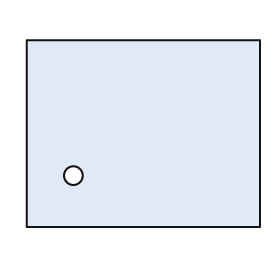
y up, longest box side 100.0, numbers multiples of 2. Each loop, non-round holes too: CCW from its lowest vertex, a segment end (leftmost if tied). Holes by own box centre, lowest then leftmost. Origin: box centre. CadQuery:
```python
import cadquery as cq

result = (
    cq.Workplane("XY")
    .moveTo(-50.0, -40.0)
    .lineTo(50.0, -40.0)
    .lineTo(50.0, 40.0)
    .lineTo(-50.0, 40.0)
    .close()
    .moveTo(-30.0, -18.0)
    .circle(4.0)
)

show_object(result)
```